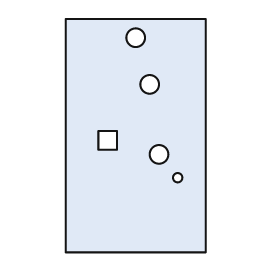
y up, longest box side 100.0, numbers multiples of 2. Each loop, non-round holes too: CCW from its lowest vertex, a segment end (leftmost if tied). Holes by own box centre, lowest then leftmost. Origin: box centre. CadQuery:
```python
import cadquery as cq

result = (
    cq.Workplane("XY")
    .moveTo(-30.0, -50.0)
    .lineTo(30.0, -50.0)
    .lineTo(30.0, 50.0)
    .lineTo(-30.0, 50.0)
    .close()
    .moveTo(18.0, -18.0)
    .circle(2.0)
    .moveTo(10.0, -8.0)
    .circle(4.0)
    .moveTo(-16.0, -6.0)
    .lineTo(-8.0, -6.0)
    .lineTo(-8.0, 2.0)
    .lineTo(-16.0, 2.0)
    .close()
    .moveTo(6.0, 22.0)
    .circle(4.0)
    .moveTo(0.0, 42.0)
    .circle(4.0)
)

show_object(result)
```